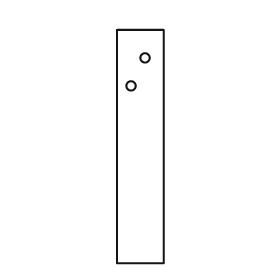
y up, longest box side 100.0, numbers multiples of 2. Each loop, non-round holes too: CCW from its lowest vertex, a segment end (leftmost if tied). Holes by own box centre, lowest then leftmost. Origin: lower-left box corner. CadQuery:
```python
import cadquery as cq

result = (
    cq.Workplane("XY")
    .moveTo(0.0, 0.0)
    .lineTo(20.0, 0.0)
    .lineTo(20.0, 100.0)
    .lineTo(0.0, 100.0)
    .close()
    .moveTo(6.0, 76.0)
    .circle(2.0)
    .moveTo(12.0, 88.0)
    .circle(2.0)
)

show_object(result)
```